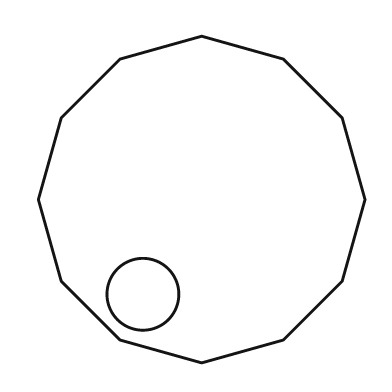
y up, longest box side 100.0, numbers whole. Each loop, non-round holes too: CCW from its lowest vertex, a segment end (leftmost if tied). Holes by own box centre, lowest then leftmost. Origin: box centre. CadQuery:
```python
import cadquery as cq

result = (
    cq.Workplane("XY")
    .moveTo(0.0, -50.0)
    .lineTo(25.0, -43.0)
    .lineTo(43.0, -25.0)
    .lineTo(50.0, 0.0)
    .lineTo(43.0, 25.0)
    .lineTo(25.0, 43.0)
    .lineTo(0.0, 50.0)
    .lineTo(-25.0, 43.0)
    .lineTo(-43.0, 25.0)
    .lineTo(-50.0, 0.0)
    .lineTo(-43.0, -25.0)
    .lineTo(-25.0, -43.0)
    .close()
    .moveTo(-18.0, -29.0)
    .circle(11.0)
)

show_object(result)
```